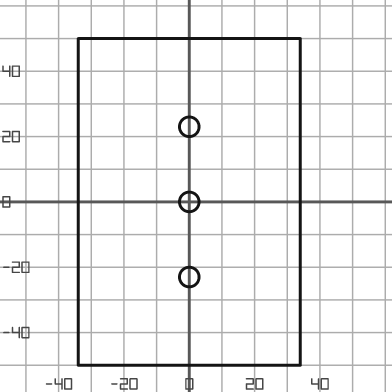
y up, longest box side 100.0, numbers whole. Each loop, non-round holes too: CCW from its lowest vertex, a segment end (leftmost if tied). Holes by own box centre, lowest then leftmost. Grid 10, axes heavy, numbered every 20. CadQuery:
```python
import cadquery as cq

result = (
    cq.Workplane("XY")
    .moveTo(-34.0, -50.0)
    .lineTo(34.0, -50.0)
    .lineTo(34.0, 50.0)
    .lineTo(-34.0, 50.0)
    .close()
    .moveTo(0.0, -23.0)
    .circle(3.0)
    .moveTo(0.0, 0.0)
    .circle(3.0)
    .moveTo(0.0, 23.0)
    .circle(3.0)
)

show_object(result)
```